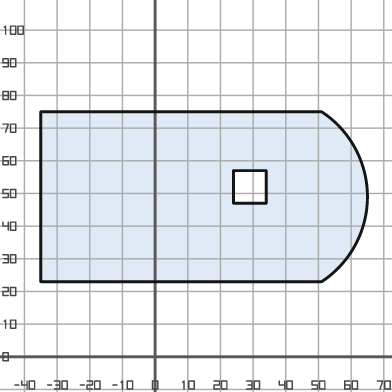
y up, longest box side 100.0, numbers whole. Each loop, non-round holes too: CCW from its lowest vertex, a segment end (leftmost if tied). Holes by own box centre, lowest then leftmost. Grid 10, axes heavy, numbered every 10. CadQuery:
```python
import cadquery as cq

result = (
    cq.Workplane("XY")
    .moveTo(-35.0, 23.0)
    .lineTo(51.0, 23.0)
    .threePointArc((65.0, 49.0), (51.0, 75.0))
    .lineTo(-35.0, 75.0)
    .close()
    .moveTo(24.0, 47.0)
    .lineTo(34.0, 47.0)
    .lineTo(34.0, 57.0)
    .lineTo(24.0, 57.0)
    .close()
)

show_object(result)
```